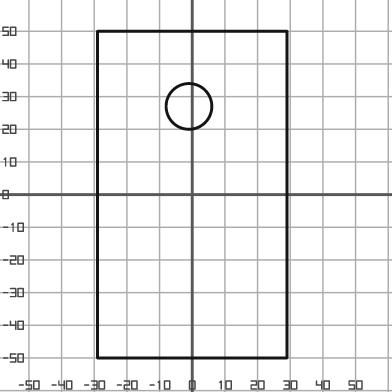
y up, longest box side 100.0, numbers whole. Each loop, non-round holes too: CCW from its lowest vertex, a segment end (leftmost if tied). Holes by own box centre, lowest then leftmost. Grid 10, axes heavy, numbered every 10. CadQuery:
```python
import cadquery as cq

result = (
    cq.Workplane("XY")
    .moveTo(-29.0, -50.0)
    .lineTo(29.0, -50.0)
    .lineTo(29.0, 50.0)
    .lineTo(-29.0, 50.0)
    .close()
    .moveTo(-1.0, 27.0)
    .circle(7.0)
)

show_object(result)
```